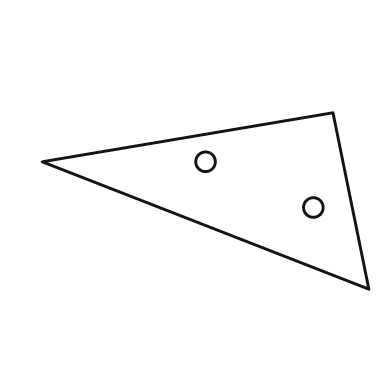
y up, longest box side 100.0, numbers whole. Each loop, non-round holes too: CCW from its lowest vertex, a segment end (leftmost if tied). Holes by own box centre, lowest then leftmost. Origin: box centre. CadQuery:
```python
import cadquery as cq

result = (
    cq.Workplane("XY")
    .moveTo(50.0, -27.0)
    .lineTo(39.0, 27.0)
    .lineTo(-50.0, 12.0)
    .close()
    .moveTo(33.0, -2.0)
    .circle(3.0)
    .moveTo(0.0, 12.0)
    .circle(3.0)
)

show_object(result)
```